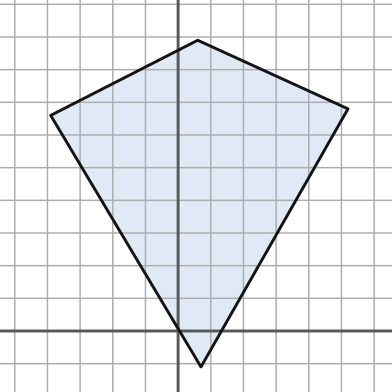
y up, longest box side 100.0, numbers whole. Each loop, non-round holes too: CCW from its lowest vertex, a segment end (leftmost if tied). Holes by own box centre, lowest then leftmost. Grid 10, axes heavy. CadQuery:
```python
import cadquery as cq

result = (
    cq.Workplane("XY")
    .moveTo(7.0, -11.0)
    .lineTo(52.0, 68.0)
    .lineTo(6.0, 89.0)
    .lineTo(-39.0, 66.0)
    .close()
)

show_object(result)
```